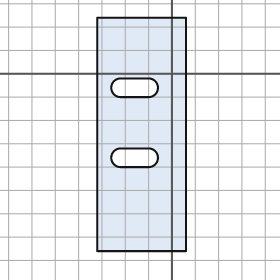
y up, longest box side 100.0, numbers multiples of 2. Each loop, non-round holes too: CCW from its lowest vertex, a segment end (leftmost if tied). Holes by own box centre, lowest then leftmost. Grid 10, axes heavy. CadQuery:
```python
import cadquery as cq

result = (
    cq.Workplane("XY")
    .moveTo(-32.0, -76.0)
    .lineTo(6.0, -76.0)
    .lineTo(6.0, 24.0)
    .lineTo(-32.0, 24.0)
    .close()
    .moveTo(-22.0, -40.0)
    .lineTo(-10.0, -40.0)
    .threePointArc((-6.0, -36.0), (-10.0, -32.0))
    .lineTo(-22.0, -32.0)
    .threePointArc((-26.0, -36.0), (-22.0, -40.0))
    .close()
    .moveTo(-22.0, -10.0)
    .lineTo(-10.0, -10.0)
    .threePointArc((-6.0, -6.0), (-10.0, -2.0))
    .lineTo(-22.0, -2.0)
    .threePointArc((-26.0, -6.0), (-22.0, -10.0))
    .close()
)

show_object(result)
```